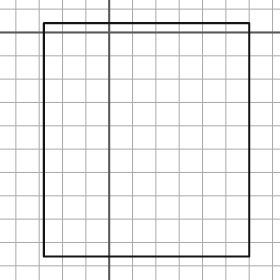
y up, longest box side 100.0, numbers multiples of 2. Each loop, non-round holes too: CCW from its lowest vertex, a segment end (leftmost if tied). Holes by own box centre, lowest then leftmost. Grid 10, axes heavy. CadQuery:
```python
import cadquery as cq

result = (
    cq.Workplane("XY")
    .moveTo(-28.0, -96.0)
    .lineTo(60.0, -96.0)
    .lineTo(60.0, 4.0)
    .lineTo(-28.0, 4.0)
    .close()
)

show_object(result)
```